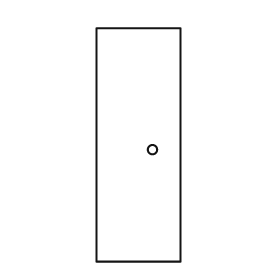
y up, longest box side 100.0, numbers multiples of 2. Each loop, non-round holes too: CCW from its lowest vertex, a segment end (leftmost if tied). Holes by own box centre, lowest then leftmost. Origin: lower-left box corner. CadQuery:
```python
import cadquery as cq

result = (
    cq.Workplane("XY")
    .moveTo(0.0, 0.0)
    .lineTo(36.0, 0.0)
    .lineTo(36.0, 100.0)
    .lineTo(0.0, 100.0)
    .close()
    .moveTo(24.0, 48.0)
    .circle(2.0)
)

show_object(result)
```